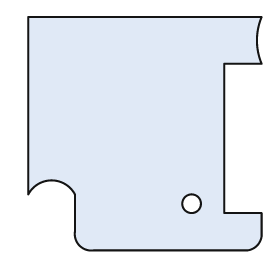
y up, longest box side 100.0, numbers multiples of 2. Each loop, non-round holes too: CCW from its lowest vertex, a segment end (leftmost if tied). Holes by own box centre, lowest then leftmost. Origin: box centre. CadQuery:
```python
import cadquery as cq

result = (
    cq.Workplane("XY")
    .moveTo(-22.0, -50.0)
    .lineTo(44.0, -50.0)
    .threePointArc((48.0, -48.0), (50.0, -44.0))
    .lineTo(50.0, -34.0)
    .lineTo(34.0, -34.0)
    .lineTo(34.0, 30.0)
    .lineTo(50.0, 30.0)
    .threePointArc((48.0, 40.0), (50.0, 50.0))
    .lineTo(-50.0, 50.0)
    .lineTo(-50.0, -26.0)
    .threePointArc((-40.0, -20.0), (-30.0, -26.0))
    .lineTo(-30.0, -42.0)
    .threePointArc((-28.0, -48.0), (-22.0, -50.0))
    .close()
    .moveTo(20.0, -30.0)
    .circle(4.0)
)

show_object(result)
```